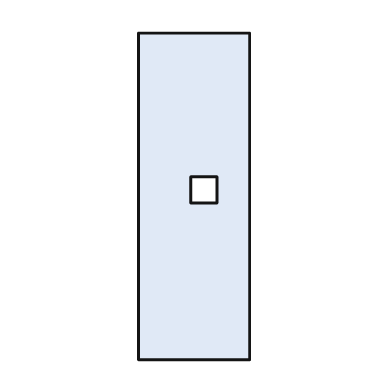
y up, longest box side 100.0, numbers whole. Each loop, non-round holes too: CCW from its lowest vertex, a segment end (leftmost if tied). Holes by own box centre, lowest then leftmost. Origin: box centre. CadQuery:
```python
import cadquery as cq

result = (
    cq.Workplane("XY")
    .moveTo(-17.0, -50.0)
    .lineTo(17.0, -50.0)
    .lineTo(17.0, 50.0)
    .lineTo(-17.0, 50.0)
    .close()
    .moveTo(-1.0, -2.0)
    .lineTo(7.0, -2.0)
    .lineTo(7.0, 6.0)
    .lineTo(-1.0, 6.0)
    .close()
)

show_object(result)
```